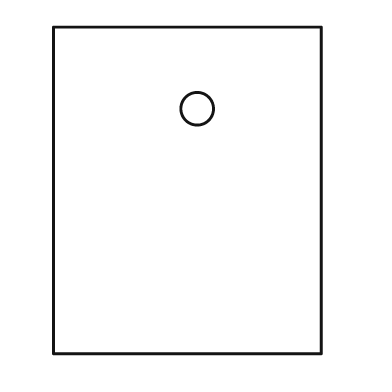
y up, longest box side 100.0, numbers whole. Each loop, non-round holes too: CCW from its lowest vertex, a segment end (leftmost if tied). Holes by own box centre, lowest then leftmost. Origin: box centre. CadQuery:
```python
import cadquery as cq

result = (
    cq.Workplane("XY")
    .moveTo(-41.0, -50.0)
    .lineTo(41.0, -50.0)
    .lineTo(41.0, 50.0)
    .lineTo(-41.0, 50.0)
    .close()
    .moveTo(3.0, 25.0)
    .circle(5.0)
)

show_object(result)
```